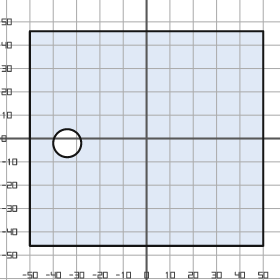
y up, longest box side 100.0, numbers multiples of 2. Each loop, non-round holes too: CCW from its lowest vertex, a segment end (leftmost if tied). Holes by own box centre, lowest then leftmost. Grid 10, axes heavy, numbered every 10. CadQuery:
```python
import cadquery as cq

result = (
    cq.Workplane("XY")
    .moveTo(-50.0, -46.0)
    .lineTo(50.0, -46.0)
    .lineTo(50.0, 46.0)
    .lineTo(-50.0, 46.0)
    .close()
    .moveTo(-34.0, -2.0)
    .circle(6.0)
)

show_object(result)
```